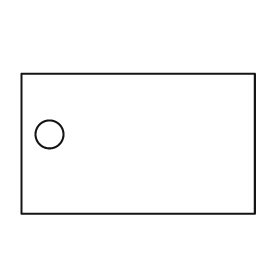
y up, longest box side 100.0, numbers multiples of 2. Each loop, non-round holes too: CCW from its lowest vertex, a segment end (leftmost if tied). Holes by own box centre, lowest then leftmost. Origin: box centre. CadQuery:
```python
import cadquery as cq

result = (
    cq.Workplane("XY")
    .moveTo(-50.0, -30.0)
    .lineTo(50.0, -30.0)
    .lineTo(50.0, 30.0)
    .lineTo(-50.0, 30.0)
    .close()
    .moveTo(-38.0, 4.0)
    .circle(6.0)
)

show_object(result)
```